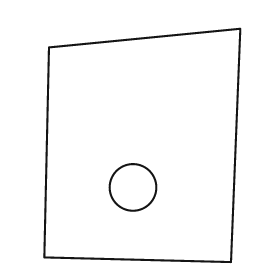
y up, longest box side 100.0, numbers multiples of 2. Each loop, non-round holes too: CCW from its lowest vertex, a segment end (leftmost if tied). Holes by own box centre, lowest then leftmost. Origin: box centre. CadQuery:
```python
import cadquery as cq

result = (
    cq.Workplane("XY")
    .moveTo(38.0, -50.0)
    .lineTo(42.0, 50.0)
    .lineTo(-40.0, 42.0)
    .lineTo(-42.0, -48.0)
    .close()
    .moveTo(-4.0, -18.0)
    .circle(10.0)
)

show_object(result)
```